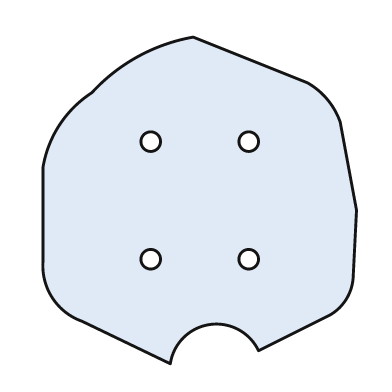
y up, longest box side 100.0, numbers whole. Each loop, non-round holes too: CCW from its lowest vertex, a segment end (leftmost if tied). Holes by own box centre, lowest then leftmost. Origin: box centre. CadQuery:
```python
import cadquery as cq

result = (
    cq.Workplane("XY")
    .moveTo(-9.0, -50.0)
    .threePointArc((3.0, -38.0), (18.0, -46.0))
    .lineTo(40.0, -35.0)
    .threePointArc((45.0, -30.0), (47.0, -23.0))
    .lineTo(48.0, -3.0)
    .lineTo(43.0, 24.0)
    .threePointArc((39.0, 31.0), (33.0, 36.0))
    .lineTo(-2.0, 50.0)
    .threePointArc((-19.0, 44.0), (-33.0, 33.0))
    .threePointArc((-43.0, 23.0), (-48.0, 10.0))
    .lineTo(-48.0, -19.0)
    .threePointArc((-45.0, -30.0), (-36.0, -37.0))
    .close()
    .moveTo(-15.0, -18.0)
    .circle(3.0)
    .moveTo(15.0, -18.0)
    .circle(3.0)
    .moveTo(-15.0, 18.0)
    .circle(3.0)
    .moveTo(15.0, 18.0)
    .circle(3.0)
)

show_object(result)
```